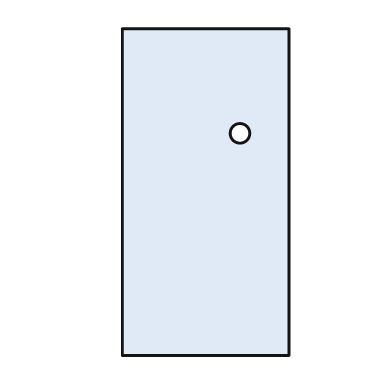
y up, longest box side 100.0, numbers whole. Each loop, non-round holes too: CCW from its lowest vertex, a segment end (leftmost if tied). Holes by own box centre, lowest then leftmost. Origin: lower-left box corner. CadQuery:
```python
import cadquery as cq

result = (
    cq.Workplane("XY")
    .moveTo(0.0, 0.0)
    .lineTo(51.0, 0.0)
    .lineTo(51.0, 100.0)
    .lineTo(0.0, 100.0)
    .close()
    .moveTo(36.0, 68.0)
    .circle(3.0)
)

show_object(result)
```